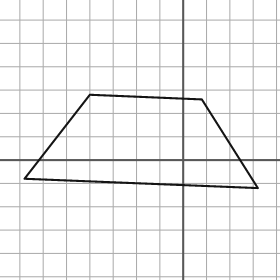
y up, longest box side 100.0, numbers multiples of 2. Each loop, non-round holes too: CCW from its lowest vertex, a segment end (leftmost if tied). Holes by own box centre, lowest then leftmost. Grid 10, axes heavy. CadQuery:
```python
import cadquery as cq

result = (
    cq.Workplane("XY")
    .moveTo(32.0, -12.0)
    .lineTo(8.0, 26.0)
    .lineTo(-40.0, 28.0)
    .lineTo(-68.0, -8.0)
    .close()
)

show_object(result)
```